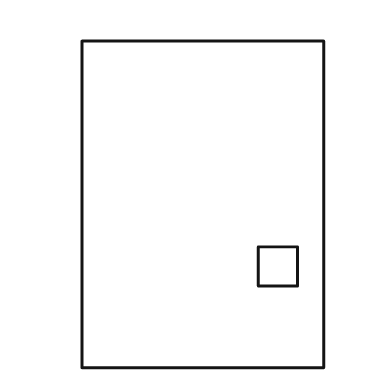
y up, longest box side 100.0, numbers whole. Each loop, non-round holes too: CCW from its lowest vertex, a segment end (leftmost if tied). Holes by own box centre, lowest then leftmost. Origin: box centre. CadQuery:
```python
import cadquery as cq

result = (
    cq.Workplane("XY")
    .moveTo(-37.0, -50.0)
    .lineTo(37.0, -50.0)
    .lineTo(37.0, 50.0)
    .lineTo(-37.0, 50.0)
    .close()
    .moveTo(17.0, -25.0)
    .lineTo(29.0, -25.0)
    .lineTo(29.0, -13.0)
    .lineTo(17.0, -13.0)
    .close()
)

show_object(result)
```